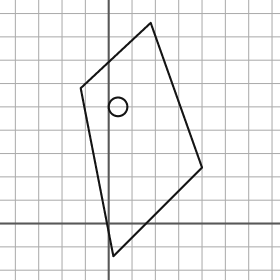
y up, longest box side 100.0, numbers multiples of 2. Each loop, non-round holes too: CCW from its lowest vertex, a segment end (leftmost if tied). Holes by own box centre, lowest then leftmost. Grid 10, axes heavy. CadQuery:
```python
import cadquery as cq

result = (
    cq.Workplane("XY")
    .moveTo(2.0, -14.0)
    .lineTo(40.0, 24.0)
    .lineTo(18.0, 86.0)
    .lineTo(-12.0, 58.0)
    .close()
    .moveTo(4.0, 50.0)
    .circle(4.0)
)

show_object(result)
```